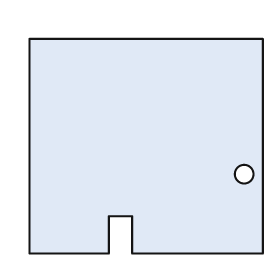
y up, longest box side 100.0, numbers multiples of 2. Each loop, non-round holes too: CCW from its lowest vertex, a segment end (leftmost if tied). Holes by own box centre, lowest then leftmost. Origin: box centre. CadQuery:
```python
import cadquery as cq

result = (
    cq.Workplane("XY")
    .moveTo(-50.0, -46.0)
    .lineTo(-16.0, -46.0)
    .lineTo(-16.0, -30.0)
    .lineTo(-6.0, -30.0)
    .lineTo(-6.0, -46.0)
    .lineTo(50.0, -46.0)
    .lineTo(50.0, 46.0)
    .lineTo(-50.0, 46.0)
    .close()
    .moveTo(42.0, -12.0)
    .circle(4.0)
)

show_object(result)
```